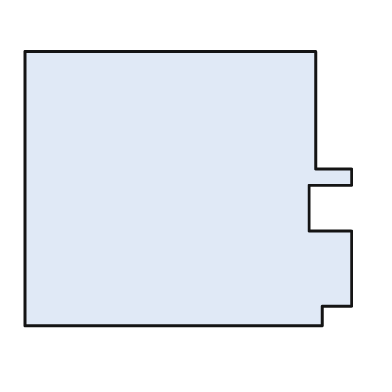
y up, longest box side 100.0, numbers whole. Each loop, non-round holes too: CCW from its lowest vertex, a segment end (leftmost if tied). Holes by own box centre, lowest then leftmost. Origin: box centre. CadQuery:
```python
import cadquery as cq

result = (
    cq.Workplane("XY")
    .moveTo(-50.0, -42.0)
    .lineTo(41.0, -42.0)
    .lineTo(41.0, -36.0)
    .lineTo(50.0, -36.0)
    .lineTo(50.0, -13.0)
    .lineTo(37.0, -13.0)
    .lineTo(37.0, 1.0)
    .lineTo(50.0, 1.0)
    .lineTo(50.0, 6.0)
    .lineTo(39.0, 6.0)
    .lineTo(39.0, 42.0)
    .lineTo(-50.0, 42.0)
    .close()
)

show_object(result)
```